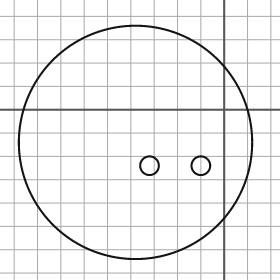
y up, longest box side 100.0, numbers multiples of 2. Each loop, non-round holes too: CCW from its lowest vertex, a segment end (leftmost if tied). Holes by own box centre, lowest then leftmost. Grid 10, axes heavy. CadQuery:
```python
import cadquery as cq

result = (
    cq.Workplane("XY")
    .moveTo(-38.0, -14.0)
    .circle(50.0)
    .moveTo(-32.0, -24.0)
    .circle(4.0)
    .moveTo(-10.0, -24.0)
    .circle(4.0)
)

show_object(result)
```